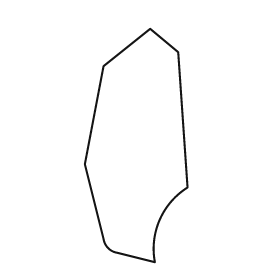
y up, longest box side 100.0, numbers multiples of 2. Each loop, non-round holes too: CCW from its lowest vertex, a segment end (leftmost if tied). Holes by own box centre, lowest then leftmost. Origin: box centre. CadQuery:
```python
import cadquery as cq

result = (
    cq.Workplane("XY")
    .moveTo(8.0, -50.0)
    .threePointArc((10.0, -32.0), (22.0, -18.0))
    .lineTo(18.0, 40.0)
    .lineTo(6.0, 50.0)
    .lineTo(-14.0, 34.0)
    .lineTo(-22.0, -8.0)
    .lineTo(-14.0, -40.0)
    .threePointArc((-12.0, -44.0), (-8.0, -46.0))
    .close()
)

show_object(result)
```